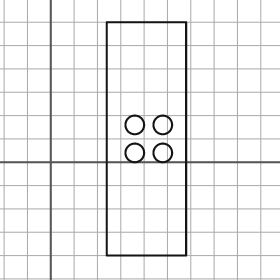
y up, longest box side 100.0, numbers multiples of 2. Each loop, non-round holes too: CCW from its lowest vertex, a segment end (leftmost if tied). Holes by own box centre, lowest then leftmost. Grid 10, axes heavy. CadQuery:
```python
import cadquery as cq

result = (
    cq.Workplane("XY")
    .moveTo(24.0, -40.0)
    .lineTo(58.0, -40.0)
    .lineTo(58.0, 60.0)
    .lineTo(24.0, 60.0)
    .close()
    .moveTo(36.0, 4.0)
    .circle(4.0)
    .moveTo(48.0, 4.0)
    .circle(4.0)
    .moveTo(36.0, 16.0)
    .circle(4.0)
    .moveTo(48.0, 16.0)
    .circle(4.0)
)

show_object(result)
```